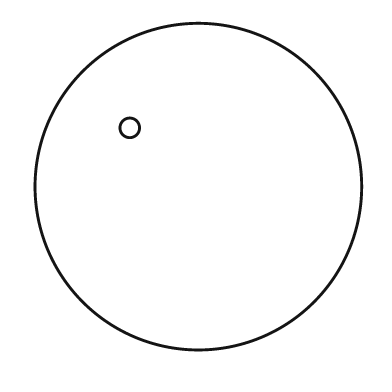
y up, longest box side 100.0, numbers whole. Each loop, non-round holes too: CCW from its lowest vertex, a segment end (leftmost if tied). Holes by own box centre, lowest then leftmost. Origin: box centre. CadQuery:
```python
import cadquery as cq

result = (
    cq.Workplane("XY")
    .moveTo(0.0, 0.0)
    .circle(50.0)
    .moveTo(-21.0, 18.0)
    .circle(3.0)
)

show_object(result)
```